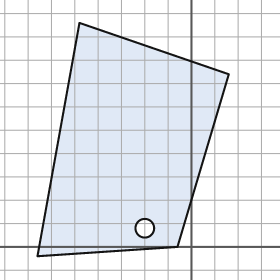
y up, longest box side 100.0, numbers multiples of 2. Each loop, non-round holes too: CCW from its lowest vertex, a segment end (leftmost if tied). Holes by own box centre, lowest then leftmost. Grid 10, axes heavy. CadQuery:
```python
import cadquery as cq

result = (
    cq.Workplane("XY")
    .moveTo(-66.0, -4.0)
    .lineTo(-6.0, 0.0)
    .lineTo(16.0, 74.0)
    .lineTo(-48.0, 96.0)
    .close()
    .moveTo(-20.0, 8.0)
    .circle(4.0)
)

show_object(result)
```